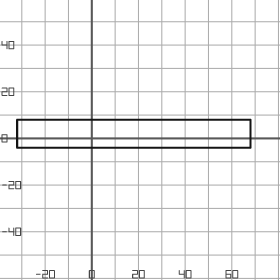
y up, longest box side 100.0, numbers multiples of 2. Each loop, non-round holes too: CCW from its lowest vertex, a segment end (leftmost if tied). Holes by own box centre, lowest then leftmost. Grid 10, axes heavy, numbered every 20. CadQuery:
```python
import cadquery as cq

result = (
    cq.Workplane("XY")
    .moveTo(-32.0, -4.0)
    .lineTo(68.0, -4.0)
    .lineTo(68.0, 8.0)
    .lineTo(-32.0, 8.0)
    .close()
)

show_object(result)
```